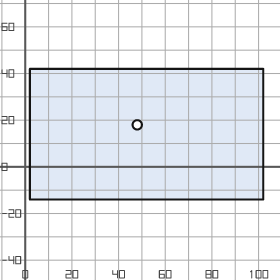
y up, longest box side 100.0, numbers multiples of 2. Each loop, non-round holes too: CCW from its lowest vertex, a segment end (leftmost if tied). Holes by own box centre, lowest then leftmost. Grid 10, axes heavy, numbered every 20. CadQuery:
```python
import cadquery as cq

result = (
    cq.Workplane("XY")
    .moveTo(2.0, -14.0)
    .lineTo(102.0, -14.0)
    .lineTo(102.0, 42.0)
    .lineTo(2.0, 42.0)
    .close()
    .moveTo(48.0, 18.0)
    .circle(2.0)
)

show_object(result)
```